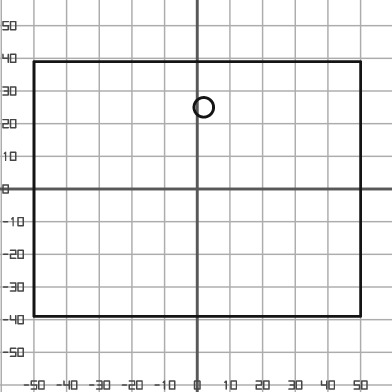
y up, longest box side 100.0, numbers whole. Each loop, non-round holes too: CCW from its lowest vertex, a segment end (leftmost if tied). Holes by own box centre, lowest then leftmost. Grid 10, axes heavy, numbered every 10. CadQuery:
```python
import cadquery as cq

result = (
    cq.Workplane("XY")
    .moveTo(-50.0, -39.0)
    .lineTo(50.0, -39.0)
    .lineTo(50.0, 39.0)
    .lineTo(-50.0, 39.0)
    .close()
    .moveTo(2.0, 25.0)
    .circle(3.0)
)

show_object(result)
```